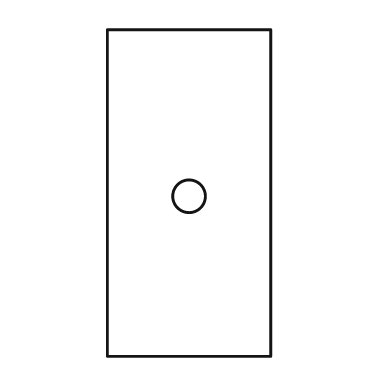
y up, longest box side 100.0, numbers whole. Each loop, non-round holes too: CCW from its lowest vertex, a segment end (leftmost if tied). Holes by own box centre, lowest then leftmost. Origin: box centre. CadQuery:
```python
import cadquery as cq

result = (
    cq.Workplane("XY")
    .moveTo(-25.0, -50.0)
    .lineTo(25.0, -50.0)
    .lineTo(25.0, 50.0)
    .lineTo(-25.0, 50.0)
    .close()
    .moveTo(0.0, -1.0)
    .circle(5.0)
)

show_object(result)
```